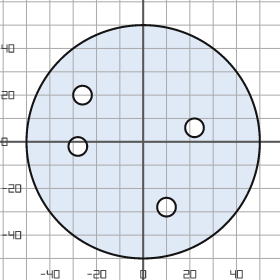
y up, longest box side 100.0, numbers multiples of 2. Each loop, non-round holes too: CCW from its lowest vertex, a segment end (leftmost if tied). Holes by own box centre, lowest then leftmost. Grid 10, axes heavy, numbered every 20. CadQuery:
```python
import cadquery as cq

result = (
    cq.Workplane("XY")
    .moveTo(0.0, 0.0)
    .circle(50.0)
    .moveTo(10.0, -28.0)
    .circle(4.0)
    .moveTo(-28.0, -2.0)
    .circle(4.0)
    .moveTo(22.0, 6.0)
    .circle(4.0)
    .moveTo(-26.0, 20.0)
    .circle(4.0)
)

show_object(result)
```